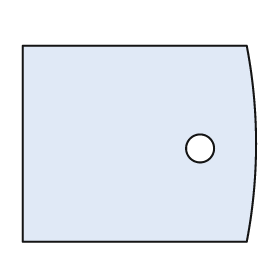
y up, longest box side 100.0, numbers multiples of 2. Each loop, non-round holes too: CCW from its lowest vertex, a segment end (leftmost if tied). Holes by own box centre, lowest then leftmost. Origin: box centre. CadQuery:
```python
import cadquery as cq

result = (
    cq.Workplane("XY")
    .moveTo(-50.0, -42.0)
    .lineTo(46.0, -42.0)
    .threePointArc((50.0, 0.0), (46.0, 42.0))
    .lineTo(-50.0, 42.0)
    .close()
    .moveTo(26.0, -2.0)
    .circle(6.0)
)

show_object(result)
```